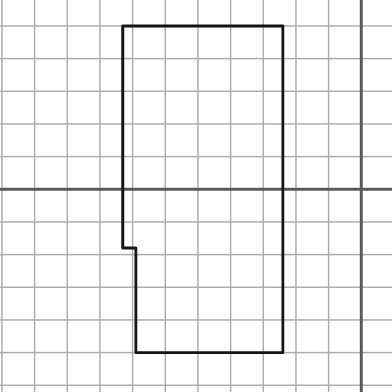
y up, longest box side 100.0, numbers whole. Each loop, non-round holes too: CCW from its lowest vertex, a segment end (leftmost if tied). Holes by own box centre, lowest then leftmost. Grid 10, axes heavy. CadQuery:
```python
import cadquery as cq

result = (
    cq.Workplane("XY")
    .moveTo(-69.0, -50.0)
    .lineTo(-24.0, -50.0)
    .lineTo(-24.0, 50.0)
    .lineTo(-73.0, 50.0)
    .lineTo(-73.0, -18.0)
    .lineTo(-69.0, -18.0)
    .close()
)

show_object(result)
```